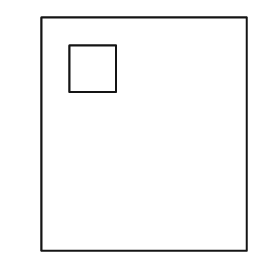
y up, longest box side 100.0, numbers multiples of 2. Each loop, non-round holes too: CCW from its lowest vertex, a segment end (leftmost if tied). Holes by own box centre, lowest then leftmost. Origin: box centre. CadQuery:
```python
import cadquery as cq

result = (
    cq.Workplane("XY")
    .moveTo(-44.0, -50.0)
    .lineTo(44.0, -50.0)
    .lineTo(44.0, 50.0)
    .lineTo(-44.0, 50.0)
    .close()
    .moveTo(-32.0, 18.0)
    .lineTo(-12.0, 18.0)
    .lineTo(-12.0, 38.0)
    .lineTo(-32.0, 38.0)
    .close()
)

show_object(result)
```